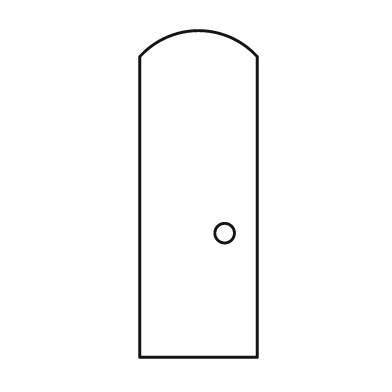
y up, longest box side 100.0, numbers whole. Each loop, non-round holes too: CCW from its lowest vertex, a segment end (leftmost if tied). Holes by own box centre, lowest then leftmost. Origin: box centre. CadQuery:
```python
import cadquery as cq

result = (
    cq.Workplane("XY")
    .moveTo(-18.0, -50.0)
    .lineTo(18.0, -50.0)
    .lineTo(18.0, 42.0)
    .threePointArc((0.0, 50.0), (-18.0, 42.0))
    .close()
    .moveTo(8.0, -12.0)
    .circle(3.0)
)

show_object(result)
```